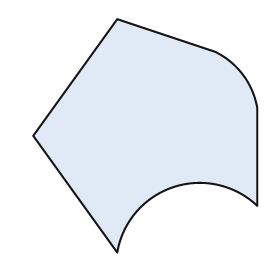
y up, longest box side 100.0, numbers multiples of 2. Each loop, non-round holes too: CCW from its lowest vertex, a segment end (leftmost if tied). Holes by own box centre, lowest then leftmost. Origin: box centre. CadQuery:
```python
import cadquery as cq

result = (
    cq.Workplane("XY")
    .moveTo(-12.0, -50.0)
    .threePointArc((12.0, -22.0), (48.0, -30.0))
    .lineTo(48.0, 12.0)
    .threePointArc((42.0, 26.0), (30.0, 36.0))
    .lineTo(-12.0, 50.0)
    .lineTo(-48.0, 0.0)
    .close()
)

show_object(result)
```